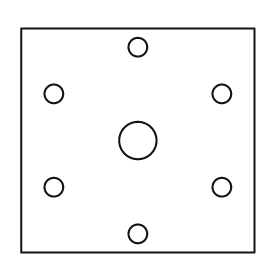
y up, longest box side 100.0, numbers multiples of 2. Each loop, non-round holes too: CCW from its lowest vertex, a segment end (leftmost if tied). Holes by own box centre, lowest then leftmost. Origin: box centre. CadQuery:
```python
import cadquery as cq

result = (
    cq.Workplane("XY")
    .moveTo(-50.0, -48.0)
    .lineTo(50.0, -48.0)
    .lineTo(50.0, 48.0)
    .lineTo(-50.0, 48.0)
    .close()
    .moveTo(0.0, -40.0)
    .circle(4.0)
    .moveTo(-36.0, -20.0)
    .circle(4.0)
    .moveTo(36.0, -20.0)
    .circle(4.0)
    .moveTo(0.0, 0.0)
    .circle(8.0)
    .moveTo(-36.0, 20.0)
    .circle(4.0)
    .moveTo(36.0, 20.0)
    .circle(4.0)
    .moveTo(0.0, 40.0)
    .circle(4.0)
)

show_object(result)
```